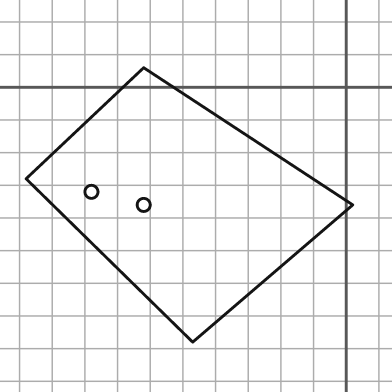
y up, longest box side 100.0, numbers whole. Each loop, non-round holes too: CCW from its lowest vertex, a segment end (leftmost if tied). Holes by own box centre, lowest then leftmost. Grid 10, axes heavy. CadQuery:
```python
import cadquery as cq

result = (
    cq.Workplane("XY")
    .moveTo(-47.0, -78.0)
    .lineTo(2.0, -36.0)
    .lineTo(-62.0, 6.0)
    .lineTo(-98.0, -28.0)
    .close()
    .moveTo(-62.0, -36.0)
    .circle(2.0)
    .moveTo(-78.0, -32.0)
    .circle(2.0)
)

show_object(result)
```